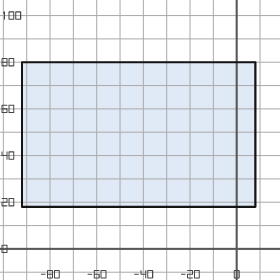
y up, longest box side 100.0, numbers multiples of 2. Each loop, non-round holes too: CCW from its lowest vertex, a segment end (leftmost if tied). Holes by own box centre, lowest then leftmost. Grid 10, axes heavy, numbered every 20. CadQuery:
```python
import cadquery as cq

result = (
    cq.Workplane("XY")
    .moveTo(-92.0, 18.0)
    .lineTo(8.0, 18.0)
    .lineTo(8.0, 80.0)
    .lineTo(-92.0, 80.0)
    .close()
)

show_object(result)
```